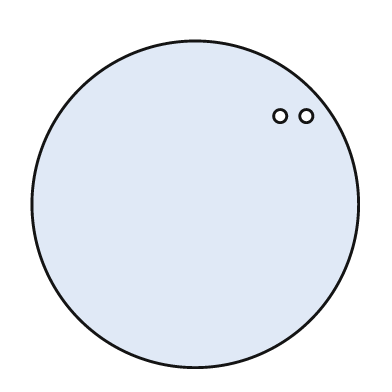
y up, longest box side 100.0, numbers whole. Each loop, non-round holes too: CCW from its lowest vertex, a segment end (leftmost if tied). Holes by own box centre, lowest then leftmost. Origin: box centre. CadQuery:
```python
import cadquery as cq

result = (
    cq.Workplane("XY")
    .moveTo(0.0, 0.0)
    .circle(50.0)
    .moveTo(26.0, 27.0)
    .circle(2.0)
    .moveTo(34.0, 27.0)
    .circle(2.0)
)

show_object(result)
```